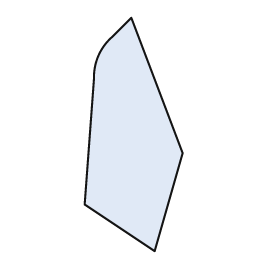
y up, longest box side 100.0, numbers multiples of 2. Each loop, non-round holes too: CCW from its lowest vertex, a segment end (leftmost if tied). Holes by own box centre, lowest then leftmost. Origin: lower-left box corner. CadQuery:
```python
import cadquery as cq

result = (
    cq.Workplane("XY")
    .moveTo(30.0, 0.0)
    .lineTo(42.0, 42.0)
    .lineTo(20.0, 100.0)
    .lineTo(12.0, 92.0)
    .threePointArc((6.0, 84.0), (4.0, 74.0))
    .lineTo(0.0, 20.0)
    .close()
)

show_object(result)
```